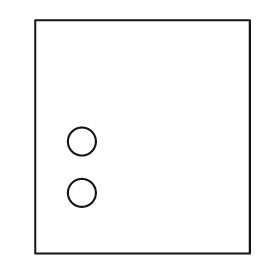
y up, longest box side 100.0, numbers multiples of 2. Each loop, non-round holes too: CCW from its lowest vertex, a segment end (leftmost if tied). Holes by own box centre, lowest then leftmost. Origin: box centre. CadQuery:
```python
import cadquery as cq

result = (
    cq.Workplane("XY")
    .moveTo(-46.0, -50.0)
    .lineTo(46.0, -50.0)
    .lineTo(46.0, 50.0)
    .lineTo(-46.0, 50.0)
    .close()
    .moveTo(-26.0, -24.0)
    .circle(6.0)
    .moveTo(-26.0, -2.0)
    .circle(6.0)
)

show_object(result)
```